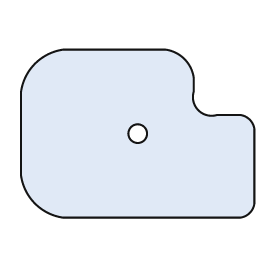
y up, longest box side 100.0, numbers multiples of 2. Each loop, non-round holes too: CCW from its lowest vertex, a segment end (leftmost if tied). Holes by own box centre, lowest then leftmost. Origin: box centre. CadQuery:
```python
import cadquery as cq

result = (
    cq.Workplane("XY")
    .moveTo(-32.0, -36.0)
    .lineTo(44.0, -36.0)
    .threePointArc((48.0, -34.0), (50.0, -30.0))
    .lineTo(50.0, 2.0)
    .threePointArc((48.0, 6.0), (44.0, 8.0))
    .lineTo(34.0, 8.0)
    .threePointArc((26.0, 10.0), (24.0, 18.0))
    .lineTo(24.0, 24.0)
    .threePointArc((20.0, 32.0), (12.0, 36.0))
    .lineTo(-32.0, 36.0)
    .threePointArc((-44.0, 30.0), (-50.0, 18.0))
    .lineTo(-50.0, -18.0)
    .threePointArc((-44.0, -30.0), (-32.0, -36.0))
    .close()
    .moveTo(0.0, 0.0)
    .circle(4.0)
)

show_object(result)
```